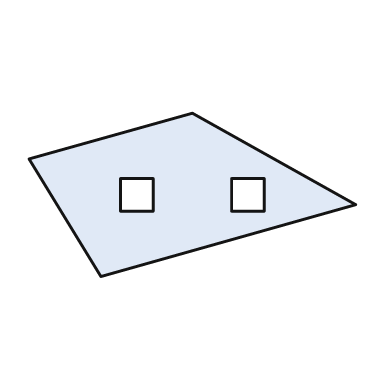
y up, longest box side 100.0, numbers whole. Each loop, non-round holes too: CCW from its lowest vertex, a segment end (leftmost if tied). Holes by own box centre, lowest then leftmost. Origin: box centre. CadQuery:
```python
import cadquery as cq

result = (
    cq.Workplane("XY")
    .moveTo(-28.0, -25.0)
    .lineTo(50.0, -3.0)
    .lineTo(0.0, 25.0)
    .lineTo(-50.0, 11.0)
    .close()
    .moveTo(-22.0, -5.0)
    .lineTo(-12.0, -5.0)
    .lineTo(-12.0, 5.0)
    .lineTo(-22.0, 5.0)
    .close()
    .moveTo(12.0, -5.0)
    .lineTo(22.0, -5.0)
    .lineTo(22.0, 5.0)
    .lineTo(12.0, 5.0)
    .close()
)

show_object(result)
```